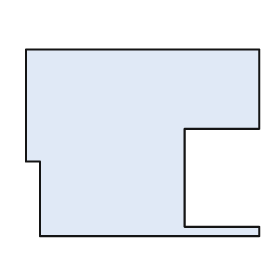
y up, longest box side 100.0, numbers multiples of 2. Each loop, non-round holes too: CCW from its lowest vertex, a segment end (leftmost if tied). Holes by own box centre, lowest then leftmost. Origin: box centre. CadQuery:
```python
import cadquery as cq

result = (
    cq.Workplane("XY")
    .moveTo(-44.0, -40.0)
    .lineTo(50.0, -40.0)
    .lineTo(50.0, -36.0)
    .lineTo(18.0, -36.0)
    .lineTo(18.0, 6.0)
    .lineTo(50.0, 6.0)
    .lineTo(50.0, 40.0)
    .lineTo(-50.0, 40.0)
    .lineTo(-50.0, -8.0)
    .lineTo(-44.0, -8.0)
    .close()
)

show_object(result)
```